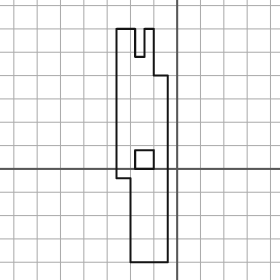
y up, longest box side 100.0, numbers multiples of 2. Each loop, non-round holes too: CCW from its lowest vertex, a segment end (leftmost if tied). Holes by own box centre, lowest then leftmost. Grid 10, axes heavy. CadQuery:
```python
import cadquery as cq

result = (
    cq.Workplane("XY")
    .moveTo(-20.0, -40.0)
    .lineTo(-4.0, -40.0)
    .lineTo(-4.0, 40.0)
    .lineTo(-10.0, 40.0)
    .lineTo(-10.0, 60.0)
    .lineTo(-14.0, 60.0)
    .lineTo(-14.0, 48.0)
    .lineTo(-18.0, 48.0)
    .lineTo(-18.0, 60.0)
    .lineTo(-26.0, 60.0)
    .lineTo(-26.0, -4.0)
    .lineTo(-20.0, -4.0)
    .close()
    .moveTo(-18.0, 0.0)
    .lineTo(-10.0, 0.0)
    .lineTo(-10.0, 8.0)
    .lineTo(-18.0, 8.0)
    .close()
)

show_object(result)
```